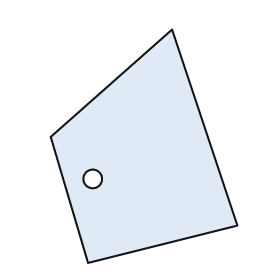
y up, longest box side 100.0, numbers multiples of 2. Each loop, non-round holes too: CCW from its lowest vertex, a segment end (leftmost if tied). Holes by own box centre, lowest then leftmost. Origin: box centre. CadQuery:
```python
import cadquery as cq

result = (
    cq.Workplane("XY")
    .moveTo(-24.0, -50.0)
    .lineTo(40.0, -34.0)
    .lineTo(12.0, 50.0)
    .lineTo(-40.0, 4.0)
    .close()
    .moveTo(-22.0, -14.0)
    .circle(4.0)
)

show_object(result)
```